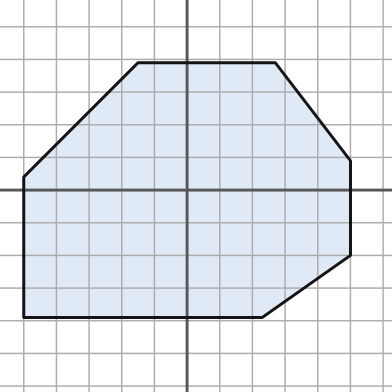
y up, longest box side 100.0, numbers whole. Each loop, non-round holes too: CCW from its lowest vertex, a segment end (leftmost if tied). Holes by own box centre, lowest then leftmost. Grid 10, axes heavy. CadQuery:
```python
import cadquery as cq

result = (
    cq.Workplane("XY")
    .moveTo(-50.0, -39.0)
    .lineTo(23.0, -39.0)
    .lineTo(50.0, -20.0)
    .lineTo(50.0, 9.0)
    .lineTo(27.0, 39.0)
    .lineTo(-15.0, 39.0)
    .lineTo(-50.0, 4.0)
    .close()
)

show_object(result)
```